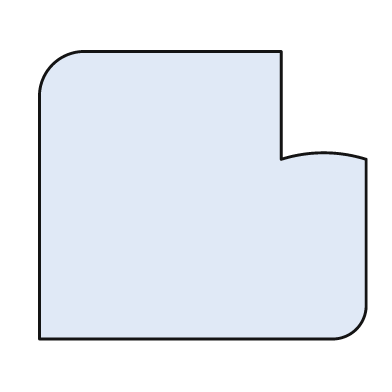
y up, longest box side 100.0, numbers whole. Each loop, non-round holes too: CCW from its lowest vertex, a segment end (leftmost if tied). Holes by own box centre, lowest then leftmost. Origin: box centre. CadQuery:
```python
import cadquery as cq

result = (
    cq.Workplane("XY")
    .moveTo(-50.0, -44.0)
    .lineTo(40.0, -44.0)
    .threePointArc((47.0, -41.0), (50.0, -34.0))
    .lineTo(50.0, 11.0)
    .threePointArc((37.0, 13.0), (24.0, 11.0))
    .lineTo(24.0, 44.0)
    .lineTo(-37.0, 44.0)
    .threePointArc((-46.0, 40.0), (-50.0, 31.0))
    .close()
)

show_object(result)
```